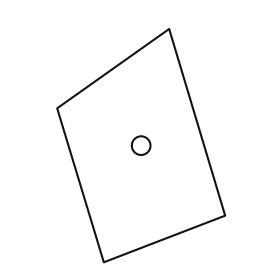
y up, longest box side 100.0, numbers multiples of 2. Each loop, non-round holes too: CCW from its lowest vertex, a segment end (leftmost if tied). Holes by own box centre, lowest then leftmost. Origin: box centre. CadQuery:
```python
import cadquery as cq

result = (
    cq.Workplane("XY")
    .moveTo(-16.0, -50.0)
    .lineTo(36.0, -30.0)
    .lineTo(12.0, 50.0)
    .lineTo(-36.0, 16.0)
    .close()
    .moveTo(0.0, 0.0)
    .circle(4.0)
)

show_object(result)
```